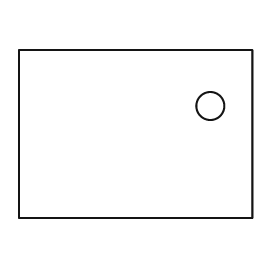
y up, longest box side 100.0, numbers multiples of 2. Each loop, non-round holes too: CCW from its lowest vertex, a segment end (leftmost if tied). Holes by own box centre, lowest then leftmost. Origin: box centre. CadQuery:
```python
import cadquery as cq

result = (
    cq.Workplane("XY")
    .moveTo(-50.0, -36.0)
    .lineTo(50.0, -36.0)
    .lineTo(50.0, 36.0)
    .lineTo(-50.0, 36.0)
    .close()
    .moveTo(32.0, 12.0)
    .circle(6.0)
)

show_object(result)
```